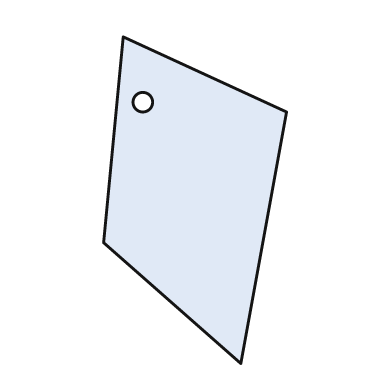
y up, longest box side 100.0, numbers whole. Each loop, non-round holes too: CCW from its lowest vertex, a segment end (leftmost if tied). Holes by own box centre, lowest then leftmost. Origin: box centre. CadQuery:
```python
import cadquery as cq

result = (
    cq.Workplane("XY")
    .moveTo(14.0, -50.0)
    .lineTo(28.0, 27.0)
    .lineTo(-22.0, 50.0)
    .lineTo(-28.0, -13.0)
    .close()
    .moveTo(-16.0, 30.0)
    .circle(3.0)
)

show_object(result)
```